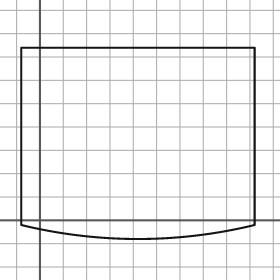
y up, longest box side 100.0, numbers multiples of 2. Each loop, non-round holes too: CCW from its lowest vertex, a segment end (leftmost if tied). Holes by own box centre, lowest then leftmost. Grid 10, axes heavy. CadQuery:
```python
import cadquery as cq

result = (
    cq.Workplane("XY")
    .moveTo(-8.0, -2.0)
    .threePointArc((42.0, -8.0), (92.0, -2.0))
    .lineTo(92.0, 74.0)
    .lineTo(-8.0, 74.0)
    .close()
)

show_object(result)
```